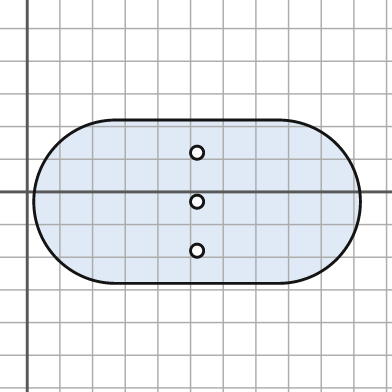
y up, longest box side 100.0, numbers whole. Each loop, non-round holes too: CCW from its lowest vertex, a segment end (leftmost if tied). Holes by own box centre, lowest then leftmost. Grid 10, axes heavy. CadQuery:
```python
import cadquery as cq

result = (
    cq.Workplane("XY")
    .moveTo(27.0, -28.0)
    .lineTo(77.0, -28.0)
    .threePointArc((102.0, -3.0), (77.0, 22.0))
    .lineTo(27.0, 22.0)
    .threePointArc((2.0, -3.0), (27.0, -28.0))
    .close()
    .moveTo(52.0, -18.0)
    .circle(2.0)
    .moveTo(52.0, -3.0)
    .circle(2.0)
    .moveTo(52.0, 12.0)
    .circle(2.0)
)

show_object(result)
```